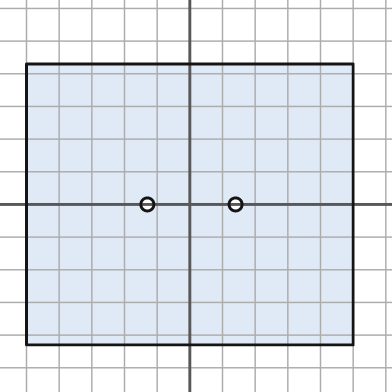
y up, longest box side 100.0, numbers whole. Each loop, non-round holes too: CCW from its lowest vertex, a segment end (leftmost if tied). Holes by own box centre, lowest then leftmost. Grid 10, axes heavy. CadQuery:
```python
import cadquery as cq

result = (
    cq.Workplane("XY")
    .moveTo(-50.0, -43.0)
    .lineTo(50.0, -43.0)
    .lineTo(50.0, 43.0)
    .lineTo(-50.0, 43.0)
    .close()
    .moveTo(-13.0, 0.0)
    .circle(2.0)
    .moveTo(14.0, 0.0)
    .circle(2.0)
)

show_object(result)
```